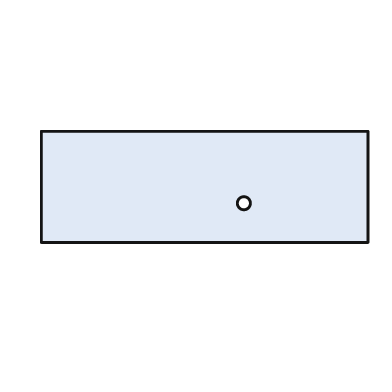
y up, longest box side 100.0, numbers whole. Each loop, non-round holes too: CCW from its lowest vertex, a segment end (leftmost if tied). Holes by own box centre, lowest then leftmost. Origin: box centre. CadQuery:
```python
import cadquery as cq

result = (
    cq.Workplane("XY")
    .moveTo(-50.0, -17.0)
    .lineTo(50.0, -17.0)
    .lineTo(50.0, 17.0)
    .lineTo(-50.0, 17.0)
    .close()
    .moveTo(12.0, -5.0)
    .circle(2.0)
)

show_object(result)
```